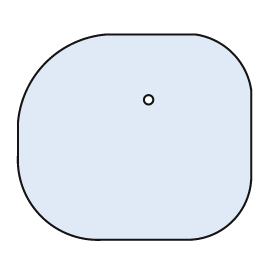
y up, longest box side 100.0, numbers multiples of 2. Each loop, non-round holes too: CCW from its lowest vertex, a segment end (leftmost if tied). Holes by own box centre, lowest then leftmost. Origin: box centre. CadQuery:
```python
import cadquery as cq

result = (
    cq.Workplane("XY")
    .moveTo(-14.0, -44.0)
    .lineTo(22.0, -44.0)
    .threePointArc((42.0, -36.0), (50.0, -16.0))
    .lineTo(50.0, 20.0)
    .threePointArc((42.0, 36.0), (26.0, 44.0))
    .lineTo(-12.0, 44.0)
    .threePointArc((-38.0, 32.0), (-50.0, 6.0))
    .lineTo(-50.0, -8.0)
    .threePointArc((-40.0, -34.0), (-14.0, -44.0))
    .close()
    .moveTo(6.0, 16.0)
    .circle(2.0)
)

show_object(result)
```